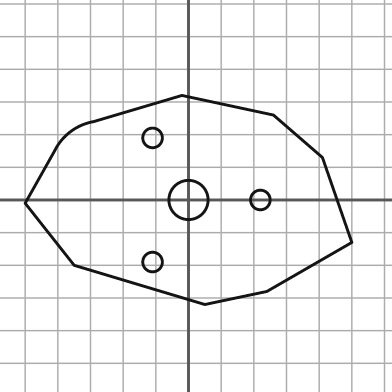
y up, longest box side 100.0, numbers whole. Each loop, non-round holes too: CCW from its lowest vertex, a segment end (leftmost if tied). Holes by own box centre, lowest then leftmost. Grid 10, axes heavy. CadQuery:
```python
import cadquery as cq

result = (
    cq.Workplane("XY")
    .moveTo(5.0, -32.0)
    .lineTo(24.0, -28.0)
    .lineTo(50.0, -13.0)
    .lineTo(41.0, 13.0)
    .lineTo(26.0, 26.0)
    .lineTo(-2.0, 32.0)
    .lineTo(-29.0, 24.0)
    .threePointArc((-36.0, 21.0), (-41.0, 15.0))
    .lineTo(-50.0, -1.0)
    .lineTo(-35.0, -20.0)
    .close()
    .moveTo(-11.0, -19.0)
    .circle(3.0)
    .moveTo(0.0, 0.0)
    .circle(6.0)
    .moveTo(22.0, 0.0)
    .circle(3.0)
    .moveTo(-11.0, 19.0)
    .circle(3.0)
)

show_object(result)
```